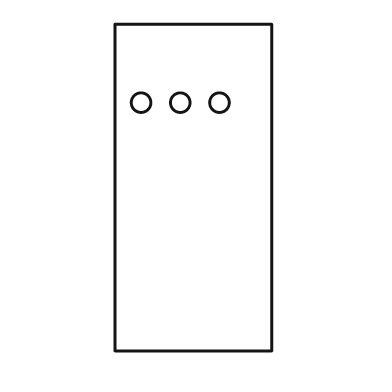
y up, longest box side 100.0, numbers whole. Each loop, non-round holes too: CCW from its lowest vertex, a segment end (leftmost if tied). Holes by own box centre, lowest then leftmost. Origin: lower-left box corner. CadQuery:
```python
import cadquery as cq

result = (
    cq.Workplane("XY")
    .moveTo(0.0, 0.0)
    .lineTo(48.0, 0.0)
    .lineTo(48.0, 100.0)
    .lineTo(0.0, 100.0)
    .close()
    .moveTo(8.0, 76.0)
    .circle(3.0)
    .moveTo(20.0, 76.0)
    .circle(3.0)
    .moveTo(32.0, 76.0)
    .circle(3.0)
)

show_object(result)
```